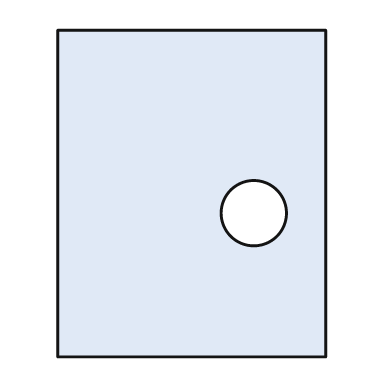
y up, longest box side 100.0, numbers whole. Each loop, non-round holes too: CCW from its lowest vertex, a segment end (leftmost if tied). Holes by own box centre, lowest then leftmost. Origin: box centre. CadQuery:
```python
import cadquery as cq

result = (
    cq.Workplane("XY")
    .moveTo(-41.0, -50.0)
    .lineTo(41.0, -50.0)
    .lineTo(41.0, 50.0)
    .lineTo(-41.0, 50.0)
    .close()
    .moveTo(19.0, -6.0)
    .circle(10.0)
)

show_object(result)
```